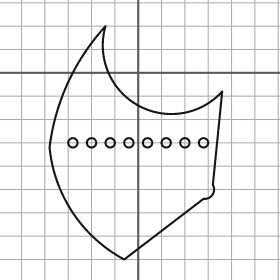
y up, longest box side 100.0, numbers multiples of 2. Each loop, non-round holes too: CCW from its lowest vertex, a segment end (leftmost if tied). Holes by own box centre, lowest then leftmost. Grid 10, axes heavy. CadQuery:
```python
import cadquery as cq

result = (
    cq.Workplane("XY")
    .moveTo(-6.0, -80.0)
    .lineTo(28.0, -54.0)
    .threePointArc((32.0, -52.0), (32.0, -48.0))
    .lineTo(36.0, -8.0)
    .threePointArc((0.0, -14.0), (-14.0, 20.0))
    .threePointArc((-30.0, -4.0), (-38.0, -32.0))
    .threePointArc((-28.0, -60.0), (-6.0, -80.0))
    .close()
    .moveTo(-28.0, -30.0)
    .circle(2.0)
    .moveTo(-20.0, -30.0)
    .circle(2.0)
    .moveTo(-12.0, -30.0)
    .circle(2.0)
    .moveTo(-4.0, -30.0)
    .circle(2.0)
    .moveTo(4.0, -30.0)
    .circle(2.0)
    .moveTo(12.0, -30.0)
    .circle(2.0)
    .moveTo(20.0, -30.0)
    .circle(2.0)
    .moveTo(28.0, -30.0)
    .circle(2.0)
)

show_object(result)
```